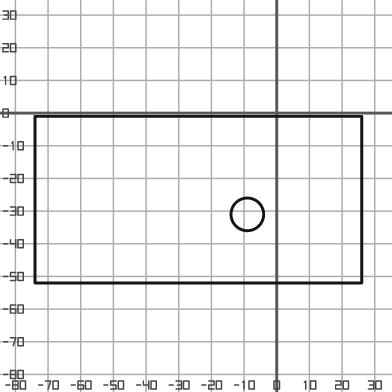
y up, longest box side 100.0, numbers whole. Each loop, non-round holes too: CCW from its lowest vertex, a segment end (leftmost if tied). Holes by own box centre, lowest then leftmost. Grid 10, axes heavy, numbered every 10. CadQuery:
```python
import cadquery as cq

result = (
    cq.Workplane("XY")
    .moveTo(-74.0, -52.0)
    .lineTo(26.0, -52.0)
    .lineTo(26.0, -1.0)
    .lineTo(-74.0, -1.0)
    .close()
    .moveTo(-9.0, -31.0)
    .circle(5.0)
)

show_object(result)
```